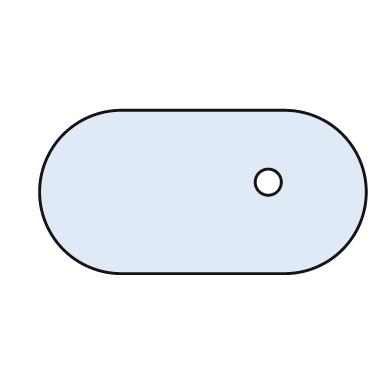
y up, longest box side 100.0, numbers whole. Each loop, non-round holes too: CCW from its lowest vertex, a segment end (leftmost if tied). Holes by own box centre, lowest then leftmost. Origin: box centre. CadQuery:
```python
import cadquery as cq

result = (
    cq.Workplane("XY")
    .moveTo(-25.0, -25.0)
    .lineTo(25.0, -25.0)
    .threePointArc((50.0, 0.0), (25.0, 25.0))
    .lineTo(-25.0, 25.0)
    .threePointArc((-50.0, 0.0), (-25.0, -25.0))
    .close()
    .moveTo(20.0, 3.0)
    .circle(4.0)
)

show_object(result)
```